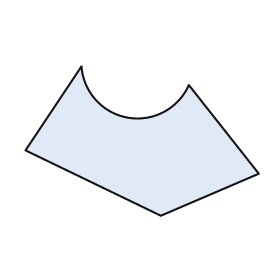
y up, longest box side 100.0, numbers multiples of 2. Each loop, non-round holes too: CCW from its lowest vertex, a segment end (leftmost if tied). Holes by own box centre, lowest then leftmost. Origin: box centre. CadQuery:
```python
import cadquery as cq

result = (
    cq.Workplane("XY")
    .moveTo(8.0, -32.0)
    .lineTo(50.0, -14.0)
    .lineTo(20.0, 24.0)
    .threePointArc((-6.0, 10.0), (-26.0, 32.0))
    .lineTo(-50.0, -4.0)
    .close()
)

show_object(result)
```